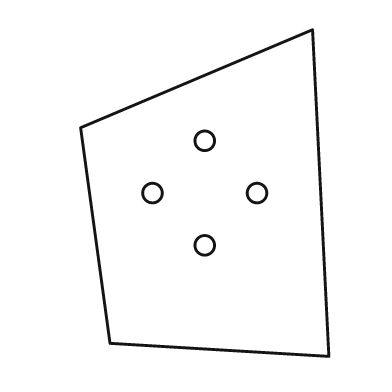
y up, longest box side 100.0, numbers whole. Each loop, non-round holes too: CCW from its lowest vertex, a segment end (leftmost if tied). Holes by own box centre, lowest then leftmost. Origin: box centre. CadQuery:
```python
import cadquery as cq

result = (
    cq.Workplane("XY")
    .moveTo(38.0, -50.0)
    .lineTo(33.0, 50.0)
    .lineTo(-38.0, 20.0)
    .lineTo(-29.0, -46.0)
    .close()
    .moveTo(0.0, -16.0)
    .circle(3.0)
    .moveTo(-16.0, 0.0)
    .circle(3.0)
    .moveTo(16.0, 0.0)
    .circle(3.0)
    .moveTo(0.0, 16.0)
    .circle(3.0)
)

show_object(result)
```